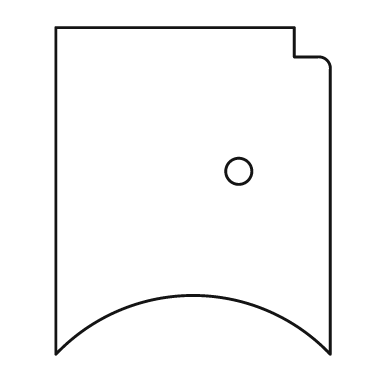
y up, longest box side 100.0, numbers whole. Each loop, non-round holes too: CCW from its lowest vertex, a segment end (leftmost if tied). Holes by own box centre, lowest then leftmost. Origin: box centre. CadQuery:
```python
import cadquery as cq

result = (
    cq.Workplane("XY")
    .moveTo(-42.0, -50.0)
    .threePointArc((0.0, -32.0), (42.0, -50.0))
    .lineTo(42.0, 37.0)
    .threePointArc((41.0, 40.0), (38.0, 41.0))
    .lineTo(31.0, 41.0)
    .lineTo(31.0, 50.0)
    .lineTo(-42.0, 50.0)
    .close()
    .moveTo(14.0, 6.0)
    .circle(4.0)
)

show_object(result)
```